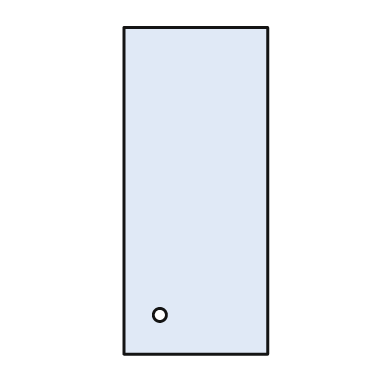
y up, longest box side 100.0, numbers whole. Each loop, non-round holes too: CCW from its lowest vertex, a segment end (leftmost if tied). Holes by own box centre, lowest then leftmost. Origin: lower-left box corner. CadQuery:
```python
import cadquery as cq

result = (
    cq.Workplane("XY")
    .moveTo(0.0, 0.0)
    .lineTo(44.0, 0.0)
    .lineTo(44.0, 100.0)
    .lineTo(0.0, 100.0)
    .close()
    .moveTo(11.0, 12.0)
    .circle(2.0)
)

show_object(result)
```